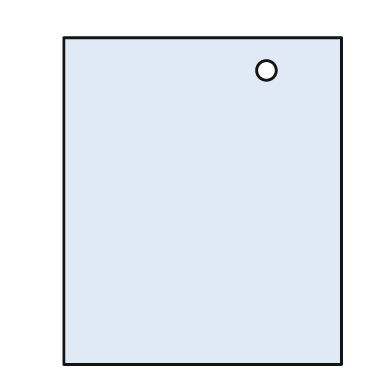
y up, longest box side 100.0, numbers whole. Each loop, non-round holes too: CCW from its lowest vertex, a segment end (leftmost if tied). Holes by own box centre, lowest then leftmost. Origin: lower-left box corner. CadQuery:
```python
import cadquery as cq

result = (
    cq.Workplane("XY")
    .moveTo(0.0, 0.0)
    .lineTo(85.0, 0.0)
    .lineTo(85.0, 100.0)
    .lineTo(0.0, 100.0)
    .close()
    .moveTo(62.0, 90.0)
    .circle(3.0)
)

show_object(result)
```